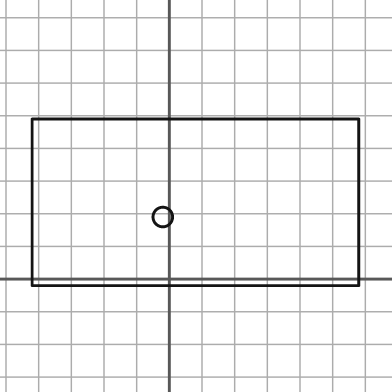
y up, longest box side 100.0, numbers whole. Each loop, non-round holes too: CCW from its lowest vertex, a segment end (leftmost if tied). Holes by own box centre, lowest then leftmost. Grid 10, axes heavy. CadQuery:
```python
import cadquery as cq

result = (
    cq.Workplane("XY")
    .moveTo(-42.0, -2.0)
    .lineTo(58.0, -2.0)
    .lineTo(58.0, 49.0)
    .lineTo(-42.0, 49.0)
    .close()
    .moveTo(-2.0, 19.0)
    .circle(3.0)
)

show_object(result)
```